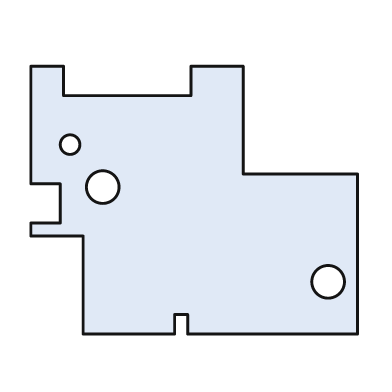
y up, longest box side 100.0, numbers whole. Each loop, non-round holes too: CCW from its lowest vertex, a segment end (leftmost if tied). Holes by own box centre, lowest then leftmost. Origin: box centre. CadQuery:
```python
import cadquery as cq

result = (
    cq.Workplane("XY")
    .moveTo(-34.0, -41.0)
    .lineTo(-6.0, -41.0)
    .lineTo(-6.0, -35.0)
    .lineTo(-2.0, -35.0)
    .lineTo(-2.0, -41.0)
    .lineTo(50.0, -41.0)
    .lineTo(50.0, 8.0)
    .lineTo(15.0, 8.0)
    .lineTo(15.0, 41.0)
    .lineTo(-1.0, 41.0)
    .lineTo(-1.0, 32.0)
    .lineTo(-40.0, 32.0)
    .lineTo(-40.0, 41.0)
    .lineTo(-50.0, 41.0)
    .lineTo(-50.0, 5.0)
    .lineTo(-41.0, 5.0)
    .lineTo(-41.0, -7.0)
    .lineTo(-50.0, -7.0)
    .lineTo(-50.0, -11.0)
    .lineTo(-34.0, -11.0)
    .close()
    .moveTo(41.0, -25.0)
    .circle(5.0)
    .moveTo(-28.0, 4.0)
    .circle(5.0)
    .moveTo(-38.0, 17.0)
    .circle(3.0)
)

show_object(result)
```